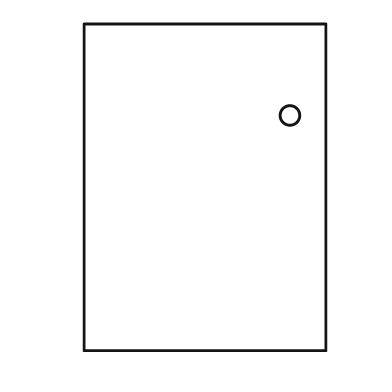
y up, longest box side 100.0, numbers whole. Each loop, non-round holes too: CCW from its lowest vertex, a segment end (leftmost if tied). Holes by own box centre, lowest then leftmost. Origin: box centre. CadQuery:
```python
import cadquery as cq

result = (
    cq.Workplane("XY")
    .moveTo(-37.0, -50.0)
    .lineTo(37.0, -50.0)
    .lineTo(37.0, 50.0)
    .lineTo(-37.0, 50.0)
    .close()
    .moveTo(26.0, 22.0)
    .circle(3.0)
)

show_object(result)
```